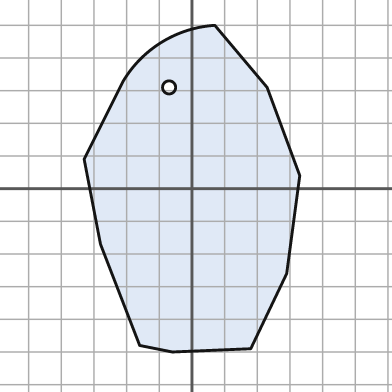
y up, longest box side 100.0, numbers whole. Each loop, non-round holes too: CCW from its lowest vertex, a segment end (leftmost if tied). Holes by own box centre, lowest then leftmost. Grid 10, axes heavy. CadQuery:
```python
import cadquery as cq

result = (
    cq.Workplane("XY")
    .moveTo(-6.0, -50.0)
    .lineTo(18.0, -49.0)
    .lineTo(29.0, -26.0)
    .lineTo(33.0, 4.0)
    .lineTo(23.0, 31.0)
    .lineTo(7.0, 50.0)
    .threePointArc((-9.0, 45.0), (-21.0, 33.0))
    .lineTo(-33.0, 9.0)
    .lineTo(-28.0, -17.0)
    .lineTo(-16.0, -48.0)
    .close()
    .moveTo(-7.0, 31.0)
    .circle(2.0)
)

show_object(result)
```